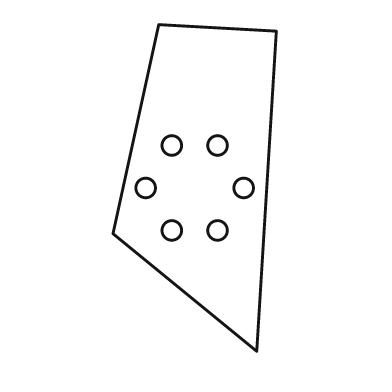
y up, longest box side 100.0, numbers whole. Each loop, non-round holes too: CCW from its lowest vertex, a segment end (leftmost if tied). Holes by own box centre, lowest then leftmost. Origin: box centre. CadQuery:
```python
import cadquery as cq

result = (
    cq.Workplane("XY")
    .moveTo(19.0, -50.0)
    .lineTo(25.0, 48.0)
    .lineTo(-11.0, 50.0)
    .lineTo(-25.0, -14.0)
    .close()
    .moveTo(-7.0, -13.0)
    .circle(3.0)
    .moveTo(7.0, -13.0)
    .circle(3.0)
    .moveTo(-15.0, 0.0)
    .circle(3.0)
    .moveTo(15.0, 0.0)
    .circle(3.0)
    .moveTo(-7.0, 13.0)
    .circle(3.0)
    .moveTo(7.0, 13.0)
    .circle(3.0)
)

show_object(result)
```